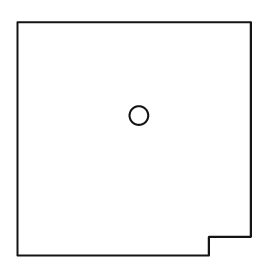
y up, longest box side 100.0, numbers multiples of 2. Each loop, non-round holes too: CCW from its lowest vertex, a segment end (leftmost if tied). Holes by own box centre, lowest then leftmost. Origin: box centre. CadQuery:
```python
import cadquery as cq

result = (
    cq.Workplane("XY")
    .moveTo(-50.0, -50.0)
    .lineTo(32.0, -50.0)
    .lineTo(32.0, -42.0)
    .lineTo(50.0, -42.0)
    .lineTo(50.0, 50.0)
    .lineTo(-50.0, 50.0)
    .close()
    .moveTo(2.0, 10.0)
    .circle(4.0)
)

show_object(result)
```